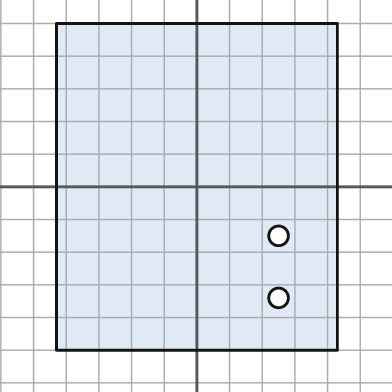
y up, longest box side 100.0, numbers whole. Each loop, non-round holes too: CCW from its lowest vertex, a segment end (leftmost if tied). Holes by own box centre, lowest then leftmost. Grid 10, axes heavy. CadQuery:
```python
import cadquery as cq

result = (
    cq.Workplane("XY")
    .moveTo(-43.0, -50.0)
    .lineTo(43.0, -50.0)
    .lineTo(43.0, 50.0)
    .lineTo(-43.0, 50.0)
    .close()
    .moveTo(25.0, -34.0)
    .circle(3.0)
    .moveTo(25.0, -15.0)
    .circle(3.0)
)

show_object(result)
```